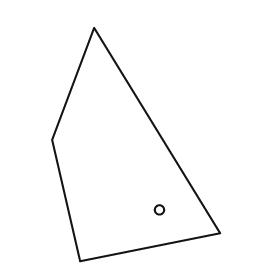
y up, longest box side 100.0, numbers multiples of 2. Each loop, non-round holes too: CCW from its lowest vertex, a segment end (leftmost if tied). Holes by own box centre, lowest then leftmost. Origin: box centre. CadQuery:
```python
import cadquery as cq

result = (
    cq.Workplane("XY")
    .moveTo(-24.0, -50.0)
    .lineTo(36.0, -38.0)
    .lineTo(-18.0, 50.0)
    .lineTo(-36.0, 2.0)
    .close()
    .moveTo(10.0, -28.0)
    .circle(2.0)
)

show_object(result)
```